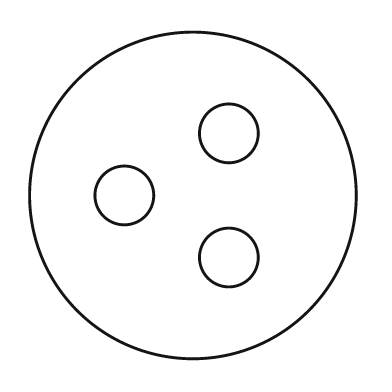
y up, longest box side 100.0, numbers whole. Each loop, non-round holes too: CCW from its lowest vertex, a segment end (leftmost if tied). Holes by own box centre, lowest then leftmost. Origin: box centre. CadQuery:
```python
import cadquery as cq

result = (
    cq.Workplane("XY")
    .moveTo(0.0, 0.0)
    .circle(50.0)
    .moveTo(11.0, -19.0)
    .circle(9.0)
    .moveTo(-21.0, 0.0)
    .circle(9.0)
    .moveTo(11.0, 19.0)
    .circle(9.0)
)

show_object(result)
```